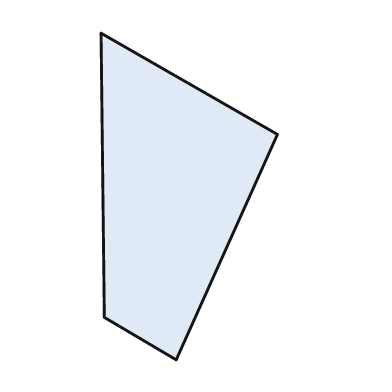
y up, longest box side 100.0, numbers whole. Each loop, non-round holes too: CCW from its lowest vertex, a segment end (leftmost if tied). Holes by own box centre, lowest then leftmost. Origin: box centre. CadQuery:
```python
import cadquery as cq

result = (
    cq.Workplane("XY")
    .moveTo(-4.0, -50.0)
    .lineTo(27.0, 19.0)
    .lineTo(-27.0, 50.0)
    .lineTo(-26.0, -37.0)
    .close()
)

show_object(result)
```